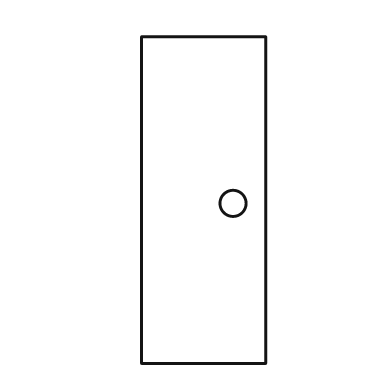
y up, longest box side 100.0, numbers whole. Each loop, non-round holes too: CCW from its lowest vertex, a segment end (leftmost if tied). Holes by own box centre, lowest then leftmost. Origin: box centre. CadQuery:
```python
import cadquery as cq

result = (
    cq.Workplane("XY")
    .moveTo(-19.0, -50.0)
    .lineTo(19.0, -50.0)
    .lineTo(19.0, 50.0)
    .lineTo(-19.0, 50.0)
    .close()
    .moveTo(9.0, -1.0)
    .circle(4.0)
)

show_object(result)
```